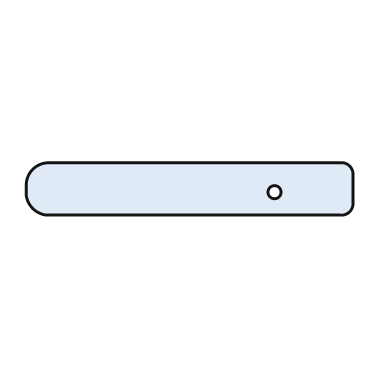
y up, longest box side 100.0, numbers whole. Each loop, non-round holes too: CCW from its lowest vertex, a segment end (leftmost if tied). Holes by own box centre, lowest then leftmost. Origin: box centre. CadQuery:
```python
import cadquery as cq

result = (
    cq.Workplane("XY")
    .moveTo(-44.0, -8.0)
    .lineTo(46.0, -8.0)
    .threePointArc((49.0, -7.0), (50.0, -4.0))
    .lineTo(50.0, 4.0)
    .threePointArc((49.0, 7.0), (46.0, 8.0))
    .lineTo(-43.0, 8.0)
    .threePointArc((-48.0, 6.0), (-50.0, 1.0))
    .lineTo(-50.0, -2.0)
    .threePointArc((-48.0, -6.0), (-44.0, -8.0))
    .close()
    .moveTo(26.0, -1.0)
    .circle(2.0)
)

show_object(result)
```